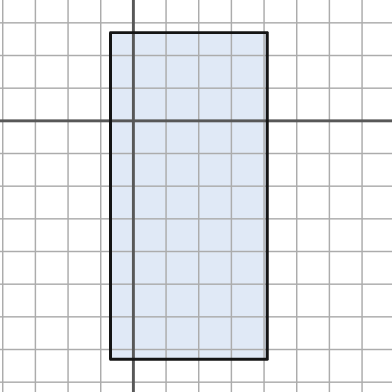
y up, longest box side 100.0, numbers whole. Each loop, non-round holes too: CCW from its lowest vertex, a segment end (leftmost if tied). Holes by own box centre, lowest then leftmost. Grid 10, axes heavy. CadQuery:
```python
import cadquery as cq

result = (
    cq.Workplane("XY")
    .moveTo(-7.0, -73.0)
    .lineTo(41.0, -73.0)
    .lineTo(41.0, 27.0)
    .lineTo(-7.0, 27.0)
    .close()
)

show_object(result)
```